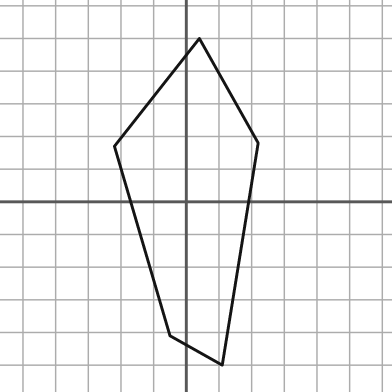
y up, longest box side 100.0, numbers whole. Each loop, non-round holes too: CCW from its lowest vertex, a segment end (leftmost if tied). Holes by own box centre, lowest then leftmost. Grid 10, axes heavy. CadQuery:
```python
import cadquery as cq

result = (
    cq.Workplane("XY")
    .moveTo(11.0, -50.0)
    .lineTo(22.0, 18.0)
    .lineTo(4.0, 50.0)
    .lineTo(-22.0, 17.0)
    .lineTo(-5.0, -41.0)
    .close()
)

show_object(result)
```